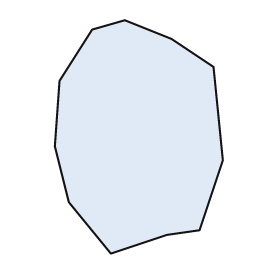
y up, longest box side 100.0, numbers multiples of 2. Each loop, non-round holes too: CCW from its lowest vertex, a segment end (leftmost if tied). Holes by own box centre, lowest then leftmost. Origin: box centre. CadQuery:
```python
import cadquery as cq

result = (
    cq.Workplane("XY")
    .moveTo(-12.0, -50.0)
    .lineTo(12.0, -42.0)
    .lineTo(26.0, -40.0)
    .lineTo(36.0, -10.0)
    .lineTo(32.0, 30.0)
    .lineTo(14.0, 42.0)
    .lineTo(-6.0, 50.0)
    .lineTo(-20.0, 46.0)
    .lineTo(-34.0, 24.0)
    .lineTo(-36.0, -4.0)
    .lineTo(-30.0, -28.0)
    .close()
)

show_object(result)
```